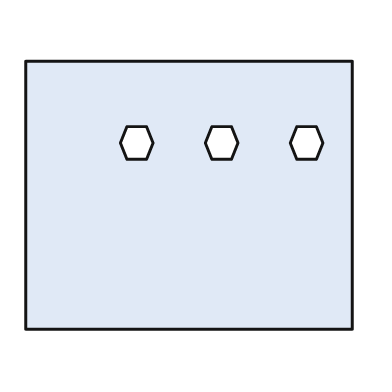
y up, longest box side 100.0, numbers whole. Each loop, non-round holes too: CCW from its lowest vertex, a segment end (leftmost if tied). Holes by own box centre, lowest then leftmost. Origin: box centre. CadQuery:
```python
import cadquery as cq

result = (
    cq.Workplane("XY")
    .moveTo(-50.0, -41.0)
    .lineTo(50.0, -41.0)
    .lineTo(50.0, 41.0)
    .lineTo(-50.0, 41.0)
    .close()
    .moveTo(-19.0, 11.0)
    .lineTo(-13.0, 11.0)
    .lineTo(-11.0, 16.0)
    .lineTo(-13.0, 21.0)
    .lineTo(-19.0, 21.0)
    .lineTo(-21.0, 16.0)
    .close()
    .moveTo(7.0, 11.0)
    .lineTo(13.0, 11.0)
    .lineTo(15.0, 16.0)
    .lineTo(13.0, 21.0)
    .lineTo(7.0, 21.0)
    .lineTo(5.0, 16.0)
    .close()
    .moveTo(33.0, 11.0)
    .lineTo(39.0, 11.0)
    .lineTo(41.0, 16.0)
    .lineTo(39.0, 21.0)
    .lineTo(33.0, 21.0)
    .lineTo(31.0, 16.0)
    .close()
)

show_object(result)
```